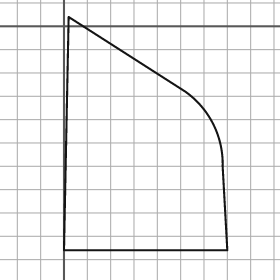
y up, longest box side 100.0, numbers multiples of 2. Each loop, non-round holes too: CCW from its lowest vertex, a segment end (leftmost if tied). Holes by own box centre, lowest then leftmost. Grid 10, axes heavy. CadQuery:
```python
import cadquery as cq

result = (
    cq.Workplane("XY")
    .moveTo(0.0, -96.0)
    .lineTo(70.0, -96.0)
    .lineTo(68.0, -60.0)
    .threePointArc((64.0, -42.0), (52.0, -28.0))
    .lineTo(2.0, 4.0)
    .close()
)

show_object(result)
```